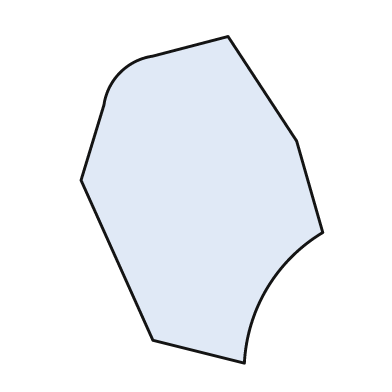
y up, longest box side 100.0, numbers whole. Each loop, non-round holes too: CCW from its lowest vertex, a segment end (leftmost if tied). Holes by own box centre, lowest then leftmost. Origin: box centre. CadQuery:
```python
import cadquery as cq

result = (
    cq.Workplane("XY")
    .moveTo(13.0, -50.0)
    .threePointArc((20.0, -27.0), (37.0, -10.0))
    .lineTo(29.0, 18.0)
    .lineTo(8.0, 50.0)
    .lineTo(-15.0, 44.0)
    .threePointArc((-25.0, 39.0), (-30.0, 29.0))
    .lineTo(-37.0, 6.0)
    .lineTo(-15.0, -43.0)
    .close()
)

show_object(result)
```